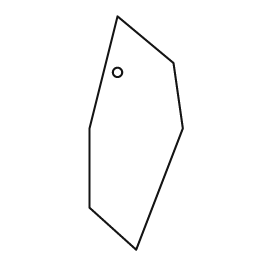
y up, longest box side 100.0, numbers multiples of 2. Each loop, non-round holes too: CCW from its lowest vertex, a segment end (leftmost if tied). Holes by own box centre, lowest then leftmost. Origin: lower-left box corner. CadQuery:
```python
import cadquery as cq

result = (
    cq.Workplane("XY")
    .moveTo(20.0, 0.0)
    .lineTo(40.0, 52.0)
    .lineTo(36.0, 80.0)
    .lineTo(12.0, 100.0)
    .lineTo(0.0, 52.0)
    .lineTo(0.0, 18.0)
    .close()
    .moveTo(12.0, 76.0)
    .circle(2.0)
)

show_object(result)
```